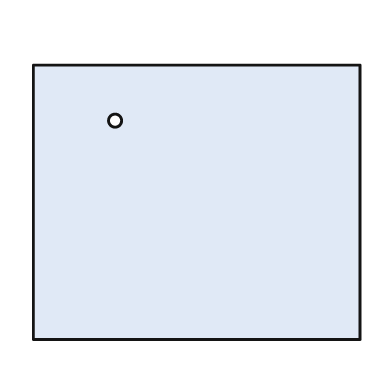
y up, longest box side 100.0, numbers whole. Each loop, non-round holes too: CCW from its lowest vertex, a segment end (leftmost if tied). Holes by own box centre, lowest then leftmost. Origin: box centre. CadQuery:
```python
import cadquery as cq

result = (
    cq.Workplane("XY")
    .moveTo(-50.0, -42.0)
    .lineTo(50.0, -42.0)
    .lineTo(50.0, 42.0)
    .lineTo(-50.0, 42.0)
    .close()
    .moveTo(-25.0, 25.0)
    .circle(2.0)
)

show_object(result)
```